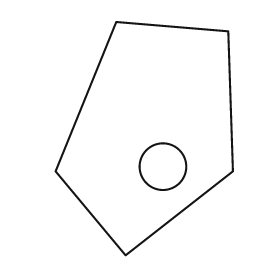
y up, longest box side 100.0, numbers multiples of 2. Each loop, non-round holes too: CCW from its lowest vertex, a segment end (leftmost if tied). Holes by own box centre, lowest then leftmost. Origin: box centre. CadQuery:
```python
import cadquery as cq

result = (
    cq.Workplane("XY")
    .moveTo(-8.0, -50.0)
    .lineTo(38.0, -14.0)
    .lineTo(36.0, 46.0)
    .lineTo(-12.0, 50.0)
    .lineTo(-38.0, -14.0)
    .close()
    .moveTo(8.0, -12.0)
    .circle(10.0)
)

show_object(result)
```